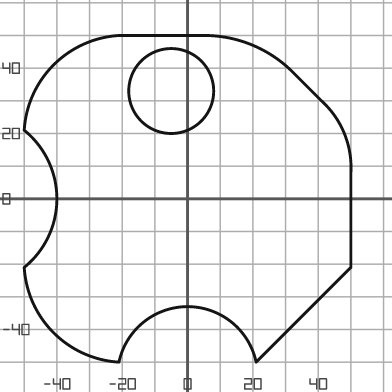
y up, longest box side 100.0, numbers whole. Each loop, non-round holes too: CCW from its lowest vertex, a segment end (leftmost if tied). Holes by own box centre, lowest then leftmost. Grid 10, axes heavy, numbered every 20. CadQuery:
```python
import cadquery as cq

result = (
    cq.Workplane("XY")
    .moveTo(-21.0, -50.0)
    .threePointArc((0.0, -33.0), (21.0, -50.0))
    .lineTo(50.0, -21.0)
    .lineTo(50.0, 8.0)
    .threePointArc((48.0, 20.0), (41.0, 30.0))
    .lineTo(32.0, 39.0)
    .threePointArc((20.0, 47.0), (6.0, 50.0))
    .lineTo(-21.0, 50.0)
    .threePointArc((-41.0, 41.0), (-50.0, 21.0))
    .threePointArc((-40.0, 0.0), (-50.0, -21.0))
    .threePointArc((-41.0, -41.0), (-21.0, -50.0))
    .close()
    .moveTo(-5.0, 33.0)
    .circle(13.0)
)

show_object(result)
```